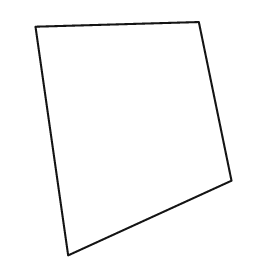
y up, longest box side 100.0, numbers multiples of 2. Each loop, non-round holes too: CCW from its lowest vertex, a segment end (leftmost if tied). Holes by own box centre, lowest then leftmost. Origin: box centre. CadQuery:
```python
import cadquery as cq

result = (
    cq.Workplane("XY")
    .moveTo(-28.0, -50.0)
    .lineTo(42.0, -18.0)
    .lineTo(28.0, 50.0)
    .lineTo(-42.0, 48.0)
    .close()
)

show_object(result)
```